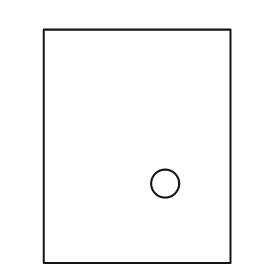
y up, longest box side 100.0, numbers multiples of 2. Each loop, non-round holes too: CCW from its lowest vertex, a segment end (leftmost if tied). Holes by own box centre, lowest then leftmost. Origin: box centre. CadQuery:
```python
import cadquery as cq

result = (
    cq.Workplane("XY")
    .moveTo(-40.0, -50.0)
    .lineTo(40.0, -50.0)
    .lineTo(40.0, 50.0)
    .lineTo(-40.0, 50.0)
    .close()
    .moveTo(12.0, -16.0)
    .circle(6.0)
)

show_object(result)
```